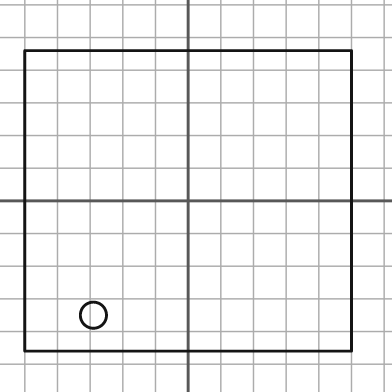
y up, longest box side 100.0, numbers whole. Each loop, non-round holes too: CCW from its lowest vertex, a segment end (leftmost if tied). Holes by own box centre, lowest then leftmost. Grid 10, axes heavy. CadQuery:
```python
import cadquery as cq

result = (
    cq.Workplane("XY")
    .moveTo(-50.0, -46.0)
    .lineTo(50.0, -46.0)
    .lineTo(50.0, 46.0)
    .lineTo(-50.0, 46.0)
    .close()
    .moveTo(-29.0, -35.0)
    .circle(4.0)
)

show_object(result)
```